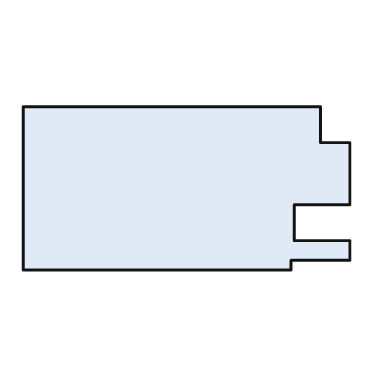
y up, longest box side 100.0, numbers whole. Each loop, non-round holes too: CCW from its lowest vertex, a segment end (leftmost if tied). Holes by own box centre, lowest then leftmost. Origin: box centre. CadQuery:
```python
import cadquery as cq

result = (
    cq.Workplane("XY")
    .moveTo(-50.0, -25.0)
    .lineTo(32.0, -25.0)
    .lineTo(32.0, -22.0)
    .lineTo(50.0, -22.0)
    .lineTo(50.0, -16.0)
    .lineTo(33.0, -16.0)
    .lineTo(33.0, -5.0)
    .lineTo(50.0, -5.0)
    .lineTo(50.0, 14.0)
    .lineTo(41.0, 14.0)
    .lineTo(41.0, 25.0)
    .lineTo(-50.0, 25.0)
    .close()
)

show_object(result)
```